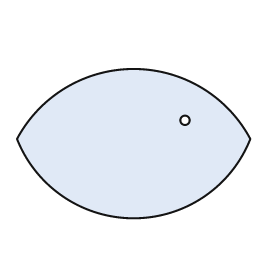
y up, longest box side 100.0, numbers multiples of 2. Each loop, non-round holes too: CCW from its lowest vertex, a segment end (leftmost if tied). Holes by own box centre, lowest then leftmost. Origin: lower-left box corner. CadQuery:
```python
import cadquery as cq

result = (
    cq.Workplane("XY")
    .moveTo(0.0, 34.0)
    .threePointArc((50.0, 0.0), (100.0, 34.0))
    .threePointArc((50.0, 64.0), (0.0, 34.0))
    .close()
    .moveTo(72.0, 42.0)
    .circle(2.0)
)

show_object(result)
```